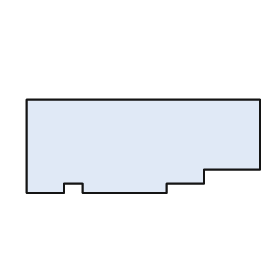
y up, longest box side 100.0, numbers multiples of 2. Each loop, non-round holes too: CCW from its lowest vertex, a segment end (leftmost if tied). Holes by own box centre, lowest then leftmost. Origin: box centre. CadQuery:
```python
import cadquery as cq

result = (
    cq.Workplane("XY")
    .moveTo(-50.0, -20.0)
    .lineTo(-34.0, -20.0)
    .lineTo(-34.0, -16.0)
    .lineTo(-26.0, -16.0)
    .lineTo(-26.0, -20.0)
    .lineTo(10.0, -20.0)
    .lineTo(10.0, -16.0)
    .lineTo(26.0, -16.0)
    .lineTo(26.0, -10.0)
    .lineTo(50.0, -10.0)
    .lineTo(50.0, 20.0)
    .lineTo(-50.0, 20.0)
    .close()
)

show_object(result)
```